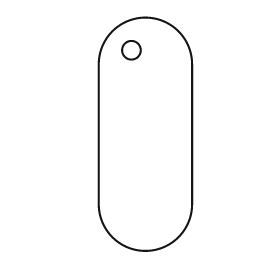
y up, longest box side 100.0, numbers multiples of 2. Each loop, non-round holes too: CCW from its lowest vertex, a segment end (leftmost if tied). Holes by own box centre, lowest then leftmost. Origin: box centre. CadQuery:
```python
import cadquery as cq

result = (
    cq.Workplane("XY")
    .moveTo(-20.0, -30.0)
    .threePointArc((0.0, -50.0), (20.0, -30.0))
    .lineTo(20.0, 30.0)
    .threePointArc((0.0, 50.0), (-20.0, 30.0))
    .close()
    .moveTo(-6.0, 36.0)
    .circle(4.0)
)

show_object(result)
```